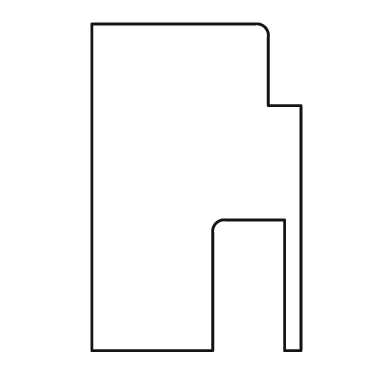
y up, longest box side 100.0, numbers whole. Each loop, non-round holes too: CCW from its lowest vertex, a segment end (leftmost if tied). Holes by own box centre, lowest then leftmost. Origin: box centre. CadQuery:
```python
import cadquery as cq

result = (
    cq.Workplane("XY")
    .moveTo(-32.0, -50.0)
    .lineTo(5.0, -50.0)
    .lineTo(5.0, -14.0)
    .threePointArc((6.0, -11.0), (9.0, -10.0))
    .lineTo(27.0, -10.0)
    .lineTo(27.0, -50.0)
    .lineTo(32.0, -50.0)
    .lineTo(32.0, 25.0)
    .lineTo(22.0, 25.0)
    .lineTo(22.0, 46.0)
    .threePointArc((21.0, 49.0), (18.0, 50.0))
    .lineTo(-32.0, 50.0)
    .close()
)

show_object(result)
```